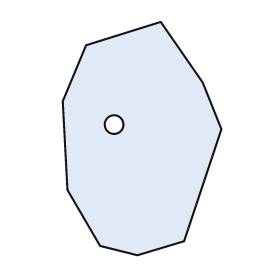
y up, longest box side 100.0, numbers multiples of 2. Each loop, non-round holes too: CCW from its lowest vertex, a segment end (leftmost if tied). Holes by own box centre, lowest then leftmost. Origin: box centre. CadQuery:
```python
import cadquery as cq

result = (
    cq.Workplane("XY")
    .moveTo(-2.0, -50.0)
    .lineTo(18.0, -44.0)
    .lineTo(34.0, 4.0)
    .lineTo(26.0, 24.0)
    .lineTo(8.0, 50.0)
    .lineTo(-24.0, 40.0)
    .lineTo(-34.0, 16.0)
    .lineTo(-32.0, -22.0)
    .lineTo(-18.0, -46.0)
    .close()
    .moveTo(-12.0, 6.0)
    .circle(4.0)
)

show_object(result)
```